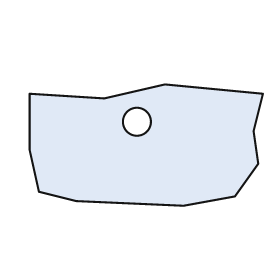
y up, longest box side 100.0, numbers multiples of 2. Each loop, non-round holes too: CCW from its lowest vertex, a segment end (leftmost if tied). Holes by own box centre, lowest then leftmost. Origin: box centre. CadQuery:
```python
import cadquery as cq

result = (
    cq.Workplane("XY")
    .moveTo(16.0, -26.0)
    .lineTo(38.0, -22.0)
    .lineTo(48.0, -8.0)
    .lineTo(46.0, 6.0)
    .lineTo(50.0, 22.0)
    .lineTo(8.0, 26.0)
    .lineTo(-18.0, 20.0)
    .lineTo(-50.0, 22.0)
    .lineTo(-50.0, -2.0)
    .lineTo(-46.0, -20.0)
    .lineTo(-30.0, -24.0)
    .close()
    .moveTo(-4.0, 10.0)
    .circle(6.0)
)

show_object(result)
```